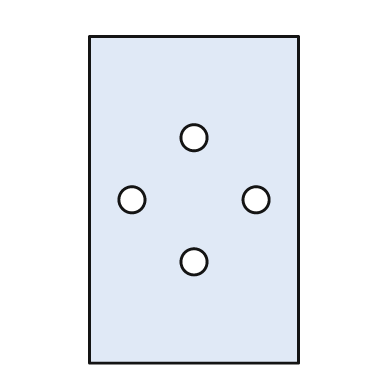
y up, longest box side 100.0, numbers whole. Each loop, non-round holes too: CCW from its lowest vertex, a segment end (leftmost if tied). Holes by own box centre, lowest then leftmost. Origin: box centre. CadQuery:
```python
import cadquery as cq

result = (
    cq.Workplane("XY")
    .moveTo(-32.0, -50.0)
    .lineTo(32.0, -50.0)
    .lineTo(32.0, 50.0)
    .lineTo(-32.0, 50.0)
    .close()
    .moveTo(0.0, -19.0)
    .circle(4.0)
    .moveTo(-19.0, 0.0)
    .circle(4.0)
    .moveTo(19.0, 0.0)
    .circle(4.0)
    .moveTo(0.0, 19.0)
    .circle(4.0)
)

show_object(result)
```